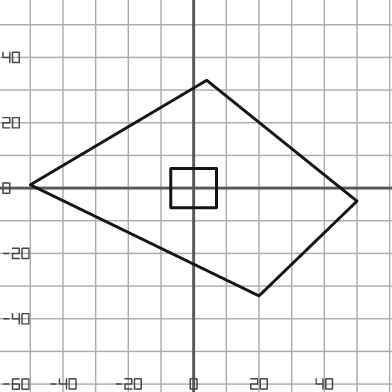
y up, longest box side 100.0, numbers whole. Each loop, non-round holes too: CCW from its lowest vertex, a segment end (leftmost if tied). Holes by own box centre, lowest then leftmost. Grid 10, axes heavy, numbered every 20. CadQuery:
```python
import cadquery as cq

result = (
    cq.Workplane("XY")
    .moveTo(20.0, -33.0)
    .lineTo(50.0, -4.0)
    .lineTo(4.0, 33.0)
    .lineTo(-50.0, 1.0)
    .close()
    .moveTo(-7.0, -6.0)
    .lineTo(7.0, -6.0)
    .lineTo(7.0, 6.0)
    .lineTo(-7.0, 6.0)
    .close()
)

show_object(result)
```